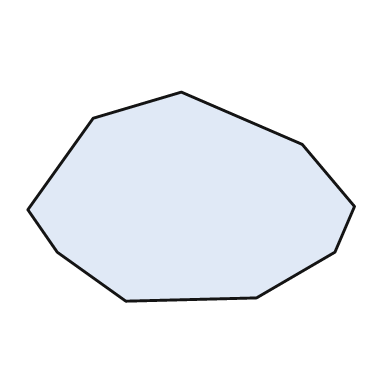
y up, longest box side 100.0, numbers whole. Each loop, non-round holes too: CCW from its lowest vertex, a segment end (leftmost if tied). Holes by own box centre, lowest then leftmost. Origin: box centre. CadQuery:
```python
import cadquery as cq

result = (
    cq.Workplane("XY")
    .moveTo(-20.0, -32.0)
    .lineTo(20.0, -31.0)
    .lineTo(44.0, -17.0)
    .lineTo(50.0, -3.0)
    .lineTo(34.0, 16.0)
    .lineTo(-3.0, 32.0)
    .lineTo(-30.0, 24.0)
    .lineTo(-50.0, -4.0)
    .lineTo(-41.0, -17.0)
    .close()
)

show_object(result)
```